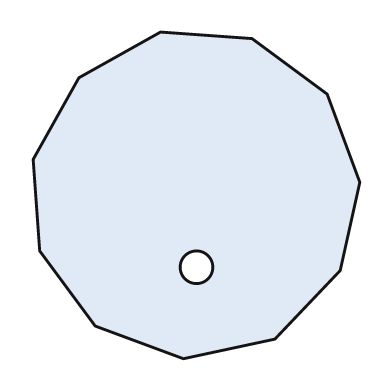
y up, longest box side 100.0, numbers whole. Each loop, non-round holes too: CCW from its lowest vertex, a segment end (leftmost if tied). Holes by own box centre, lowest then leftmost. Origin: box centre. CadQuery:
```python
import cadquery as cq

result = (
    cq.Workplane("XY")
    .moveTo(-4.0, -50.0)
    .lineTo(24.0, -44.0)
    .lineTo(44.0, -23.0)
    .lineTo(50.0, 4.0)
    .lineTo(40.0, 31.0)
    .lineTo(17.0, 48.0)
    .lineTo(-11.0, 50.0)
    .lineTo(-36.0, 36.0)
    .lineTo(-50.0, 11.0)
    .lineTo(-48.0, -17.0)
    .lineTo(-31.0, -40.0)
    .close()
    .moveTo(0.0, -22.0)
    .circle(5.0)
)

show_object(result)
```